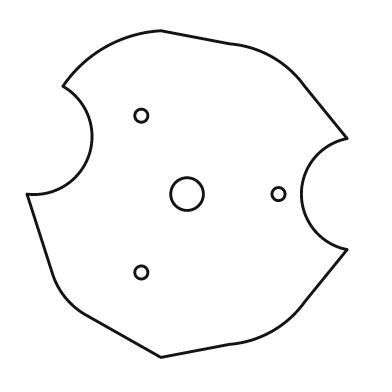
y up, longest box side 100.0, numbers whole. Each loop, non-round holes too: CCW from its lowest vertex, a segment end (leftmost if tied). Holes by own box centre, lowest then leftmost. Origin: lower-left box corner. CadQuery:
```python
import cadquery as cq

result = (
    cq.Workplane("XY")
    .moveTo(41.0, 0.0)
    .lineTo(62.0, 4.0)
    .threePointArc((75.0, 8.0), (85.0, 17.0))
    .lineTo(98.0, 33.0)
    .threePointArc((84.0, 50.0), (98.0, 67.0))
    .lineTo(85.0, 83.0)
    .threePointArc((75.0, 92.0), (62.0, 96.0))
    .lineTo(41.0, 100.0)
    .threePointArc((24.0, 95.0), (11.0, 83.0))
    .threePointArc((19.0, 62.0), (0.0, 50.0))
    .lineTo(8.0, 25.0)
    .threePointArc((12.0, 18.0), (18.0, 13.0))
    .close()
    .moveTo(35.0, 26.0)
    .circle(2.0)
    .moveTo(49.0, 50.0)
    .circle(5.0)
    .moveTo(77.0, 50.0)
    .circle(2.0)
    .moveTo(35.0, 74.0)
    .circle(2.0)
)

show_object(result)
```